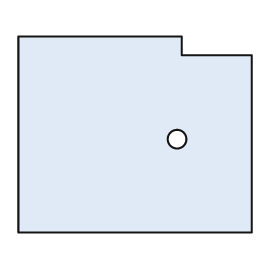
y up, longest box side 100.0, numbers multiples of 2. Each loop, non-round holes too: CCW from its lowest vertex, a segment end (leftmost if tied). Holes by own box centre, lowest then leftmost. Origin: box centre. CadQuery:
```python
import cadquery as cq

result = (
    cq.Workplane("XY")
    .moveTo(-50.0, -42.0)
    .lineTo(50.0, -42.0)
    .lineTo(50.0, 34.0)
    .lineTo(20.0, 34.0)
    .lineTo(20.0, 42.0)
    .lineTo(-50.0, 42.0)
    .close()
    .moveTo(18.0, -2.0)
    .circle(4.0)
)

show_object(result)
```